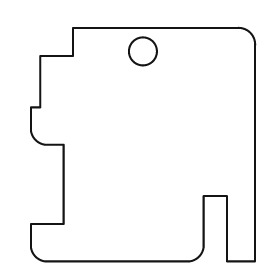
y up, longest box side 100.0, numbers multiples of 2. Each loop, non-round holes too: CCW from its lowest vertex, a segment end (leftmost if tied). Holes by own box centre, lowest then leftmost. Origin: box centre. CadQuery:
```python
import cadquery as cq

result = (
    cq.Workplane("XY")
    .moveTo(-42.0, -50.0)
    .lineTo(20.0, -50.0)
    .threePointArc((24.0, -48.0), (26.0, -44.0))
    .lineTo(26.0, -22.0)
    .lineTo(36.0, -22.0)
    .lineTo(36.0, -50.0)
    .lineTo(48.0, -50.0)
    .lineTo(48.0, 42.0)
    .threePointArc((46.0, 48.0), (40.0, 50.0))
    .lineTo(-30.0, 50.0)
    .lineTo(-30.0, 38.0)
    .lineTo(-44.0, 38.0)
    .lineTo(-44.0, 16.0)
    .lineTo(-48.0, 16.0)
    .lineTo(-48.0, 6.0)
    .threePointArc((-46.0, 2.0), (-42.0, 0.0))
    .lineTo(-34.0, 0.0)
    .lineTo(-34.0, -34.0)
    .lineTo(-48.0, -34.0)
    .lineTo(-48.0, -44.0)
    .threePointArc((-46.0, -48.0), (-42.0, -50.0))
    .close()
    .moveTo(0.0, 40.0)
    .circle(6.0)
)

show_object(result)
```